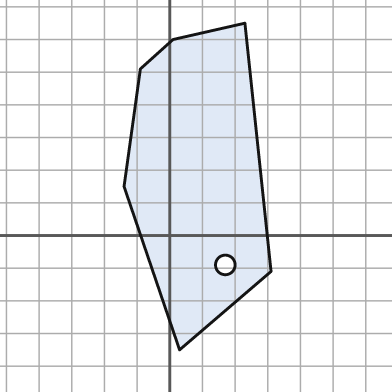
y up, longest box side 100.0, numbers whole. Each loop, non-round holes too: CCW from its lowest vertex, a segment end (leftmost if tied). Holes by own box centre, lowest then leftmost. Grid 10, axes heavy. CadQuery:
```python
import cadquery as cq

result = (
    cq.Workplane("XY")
    .moveTo(3.0, -35.0)
    .lineTo(31.0, -11.0)
    .lineTo(23.0, 65.0)
    .lineTo(1.0, 60.0)
    .lineTo(-9.0, 51.0)
    .lineTo(-14.0, 15.0)
    .close()
    .moveTo(17.0, -9.0)
    .circle(3.0)
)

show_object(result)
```